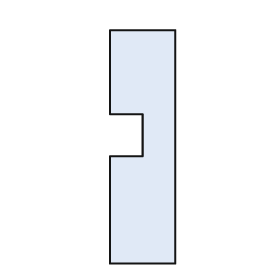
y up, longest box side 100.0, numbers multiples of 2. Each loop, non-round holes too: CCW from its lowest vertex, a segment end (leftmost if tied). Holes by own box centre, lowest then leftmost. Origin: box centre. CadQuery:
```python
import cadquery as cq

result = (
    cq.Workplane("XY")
    .moveTo(-14.0, -50.0)
    .lineTo(14.0, -50.0)
    .lineTo(14.0, 50.0)
    .lineTo(-14.0, 50.0)
    .lineTo(-14.0, 14.0)
    .lineTo(0.0, 14.0)
    .lineTo(0.0, -4.0)
    .lineTo(-14.0, -4.0)
    .close()
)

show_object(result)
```